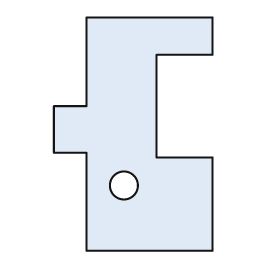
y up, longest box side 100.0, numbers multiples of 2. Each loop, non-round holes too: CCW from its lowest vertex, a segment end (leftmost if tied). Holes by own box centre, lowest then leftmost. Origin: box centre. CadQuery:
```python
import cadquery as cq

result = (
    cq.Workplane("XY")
    .moveTo(-20.0, -50.0)
    .lineTo(34.0, -50.0)
    .lineTo(34.0, -10.0)
    .lineTo(10.0, -10.0)
    .lineTo(10.0, 34.0)
    .lineTo(34.0, 34.0)
    .lineTo(34.0, 50.0)
    .lineTo(-20.0, 50.0)
    .lineTo(-20.0, 12.0)
    .lineTo(-34.0, 12.0)
    .lineTo(-34.0, -8.0)
    .lineTo(-20.0, -8.0)
    .close()
    .moveTo(-4.0, -22.0)
    .circle(6.0)
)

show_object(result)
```